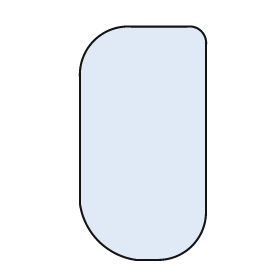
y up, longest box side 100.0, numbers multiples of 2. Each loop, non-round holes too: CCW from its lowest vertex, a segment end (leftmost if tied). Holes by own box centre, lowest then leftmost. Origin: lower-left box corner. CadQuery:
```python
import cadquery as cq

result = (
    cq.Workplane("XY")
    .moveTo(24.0, 0.0)
    .lineTo(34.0, 0.0)
    .threePointArc((48.0, 6.0), (54.0, 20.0))
    .lineTo(54.0, 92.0)
    .threePointArc((52.0, 98.0), (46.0, 100.0))
    .lineTo(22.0, 100.0)
    .threePointArc((6.0, 94.0), (0.0, 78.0))
    .lineTo(0.0, 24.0)
    .threePointArc((8.0, 8.0), (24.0, 0.0))
    .close()
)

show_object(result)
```